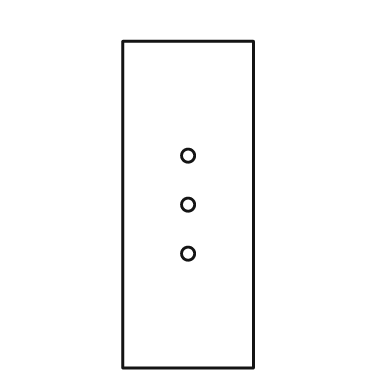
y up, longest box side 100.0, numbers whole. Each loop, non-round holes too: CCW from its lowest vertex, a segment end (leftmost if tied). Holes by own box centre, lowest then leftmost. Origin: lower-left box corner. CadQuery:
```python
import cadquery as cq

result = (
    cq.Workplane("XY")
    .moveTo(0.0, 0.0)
    .lineTo(40.0, 0.0)
    .lineTo(40.0, 100.0)
    .lineTo(0.0, 100.0)
    .close()
    .moveTo(20.0, 35.0)
    .circle(2.0)
    .moveTo(20.0, 50.0)
    .circle(2.0)
    .moveTo(20.0, 65.0)
    .circle(2.0)
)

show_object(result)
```